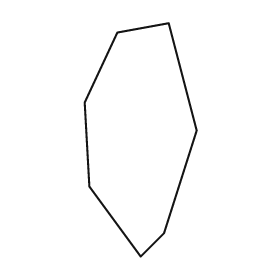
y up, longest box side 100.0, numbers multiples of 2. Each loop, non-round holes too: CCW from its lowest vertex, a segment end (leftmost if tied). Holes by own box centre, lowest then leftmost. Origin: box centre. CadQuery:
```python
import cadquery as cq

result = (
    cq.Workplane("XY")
    .moveTo(0.0, -50.0)
    .lineTo(10.0, -40.0)
    .lineTo(24.0, 4.0)
    .lineTo(12.0, 50.0)
    .lineTo(-10.0, 46.0)
    .lineTo(-24.0, 16.0)
    .lineTo(-22.0, -20.0)
    .close()
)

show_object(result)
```